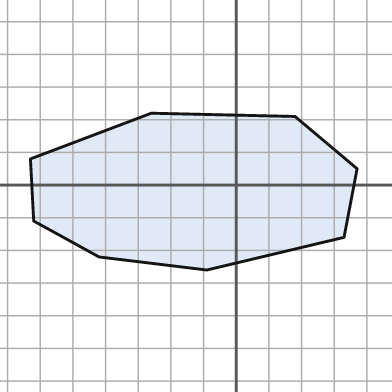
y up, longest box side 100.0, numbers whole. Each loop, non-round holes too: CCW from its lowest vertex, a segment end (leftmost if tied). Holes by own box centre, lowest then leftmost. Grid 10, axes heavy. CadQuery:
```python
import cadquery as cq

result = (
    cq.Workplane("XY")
    .moveTo(-9.0, -26.0)
    .lineTo(33.0, -16.0)
    .lineTo(37.0, 5.0)
    .lineTo(18.0, 21.0)
    .lineTo(-26.0, 22.0)
    .lineTo(-63.0, 8.0)
    .lineTo(-62.0, -11.0)
    .lineTo(-42.0, -22.0)
    .close()
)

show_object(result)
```